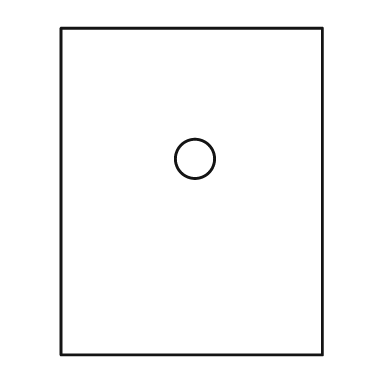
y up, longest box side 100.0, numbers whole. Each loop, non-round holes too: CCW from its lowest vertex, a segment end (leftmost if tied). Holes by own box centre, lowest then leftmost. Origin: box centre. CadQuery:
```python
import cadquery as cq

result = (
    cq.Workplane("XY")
    .moveTo(-40.0, -50.0)
    .lineTo(40.0, -50.0)
    .lineTo(40.0, 50.0)
    .lineTo(-40.0, 50.0)
    .close()
    .moveTo(1.0, 10.0)
    .circle(6.0)
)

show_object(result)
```